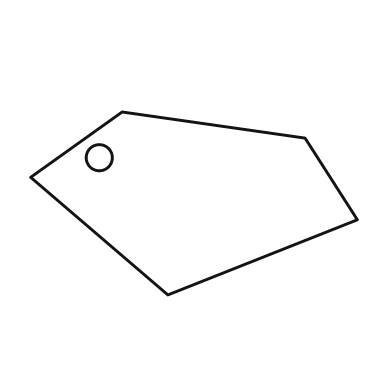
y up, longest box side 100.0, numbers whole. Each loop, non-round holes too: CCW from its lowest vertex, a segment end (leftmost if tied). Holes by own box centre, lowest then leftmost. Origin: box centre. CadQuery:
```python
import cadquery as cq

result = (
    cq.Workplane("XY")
    .moveTo(-8.0, -28.0)
    .lineTo(50.0, -5.0)
    .lineTo(34.0, 20.0)
    .lineTo(-22.0, 28.0)
    .lineTo(-50.0, 8.0)
    .close()
    .moveTo(-29.0, 14.0)
    .circle(4.0)
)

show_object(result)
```